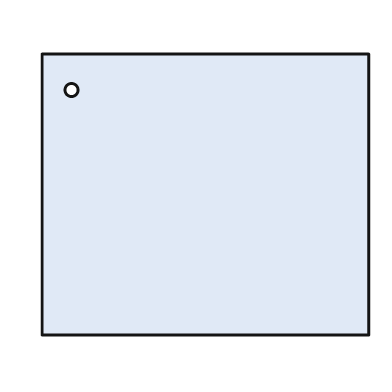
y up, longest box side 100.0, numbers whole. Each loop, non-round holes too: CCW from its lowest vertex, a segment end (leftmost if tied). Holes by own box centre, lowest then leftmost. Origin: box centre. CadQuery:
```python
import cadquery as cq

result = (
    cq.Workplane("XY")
    .moveTo(-50.0, -43.0)
    .lineTo(50.0, -43.0)
    .lineTo(50.0, 43.0)
    .lineTo(-50.0, 43.0)
    .close()
    .moveTo(-41.0, 32.0)
    .circle(2.0)
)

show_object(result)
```